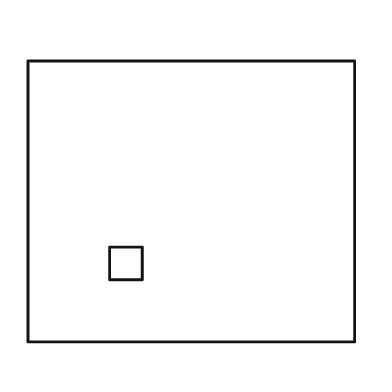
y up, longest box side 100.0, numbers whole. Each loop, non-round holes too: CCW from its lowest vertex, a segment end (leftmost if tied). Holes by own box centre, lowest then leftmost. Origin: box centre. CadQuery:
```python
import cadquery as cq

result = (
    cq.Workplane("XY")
    .moveTo(-50.0, -43.0)
    .lineTo(50.0, -43.0)
    .lineTo(50.0, 43.0)
    .lineTo(-50.0, 43.0)
    .close()
    .moveTo(-25.0, -24.0)
    .lineTo(-15.0, -24.0)
    .lineTo(-15.0, -14.0)
    .lineTo(-25.0, -14.0)
    .close()
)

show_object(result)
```